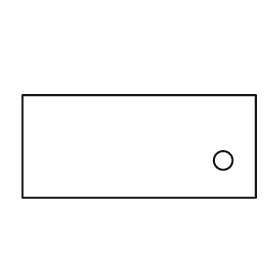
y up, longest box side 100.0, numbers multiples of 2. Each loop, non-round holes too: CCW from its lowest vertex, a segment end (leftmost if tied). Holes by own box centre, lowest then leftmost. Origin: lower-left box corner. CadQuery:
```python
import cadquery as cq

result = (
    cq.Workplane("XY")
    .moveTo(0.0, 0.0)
    .lineTo(100.0, 0.0)
    .lineTo(100.0, 44.0)
    .lineTo(0.0, 44.0)
    .close()
    .moveTo(86.0, 16.0)
    .circle(4.0)
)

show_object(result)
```